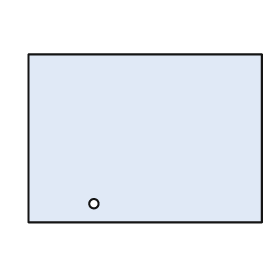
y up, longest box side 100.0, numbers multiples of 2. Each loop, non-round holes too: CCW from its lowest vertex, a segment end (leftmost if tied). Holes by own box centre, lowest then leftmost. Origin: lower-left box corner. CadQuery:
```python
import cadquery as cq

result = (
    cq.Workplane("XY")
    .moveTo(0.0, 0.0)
    .lineTo(100.0, 0.0)
    .lineTo(100.0, 72.0)
    .lineTo(0.0, 72.0)
    .close()
    .moveTo(28.0, 8.0)
    .circle(2.0)
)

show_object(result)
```